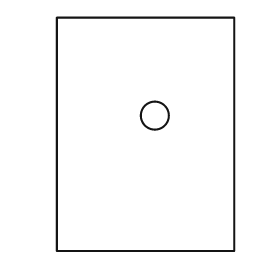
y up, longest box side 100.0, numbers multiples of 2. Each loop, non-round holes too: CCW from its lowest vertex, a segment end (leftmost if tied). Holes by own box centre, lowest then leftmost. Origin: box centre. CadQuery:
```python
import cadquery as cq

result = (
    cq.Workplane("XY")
    .moveTo(-38.0, -50.0)
    .lineTo(38.0, -50.0)
    .lineTo(38.0, 50.0)
    .lineTo(-38.0, 50.0)
    .close()
    .moveTo(4.0, 8.0)
    .circle(6.0)
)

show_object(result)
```